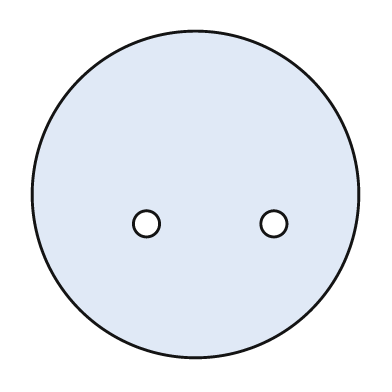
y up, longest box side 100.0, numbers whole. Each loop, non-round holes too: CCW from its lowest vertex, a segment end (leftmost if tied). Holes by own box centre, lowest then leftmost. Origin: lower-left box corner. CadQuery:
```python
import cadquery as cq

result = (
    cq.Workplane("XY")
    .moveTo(50.0, 50.0)
    .circle(50.0)
    .moveTo(35.0, 41.0)
    .circle(4.0)
    .moveTo(74.0, 41.0)
    .circle(4.0)
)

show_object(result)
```